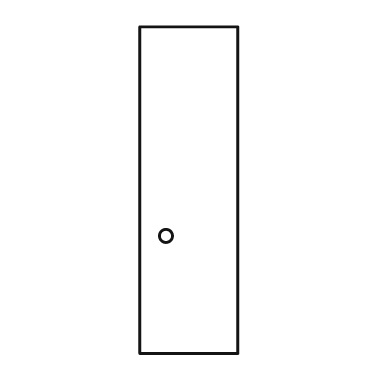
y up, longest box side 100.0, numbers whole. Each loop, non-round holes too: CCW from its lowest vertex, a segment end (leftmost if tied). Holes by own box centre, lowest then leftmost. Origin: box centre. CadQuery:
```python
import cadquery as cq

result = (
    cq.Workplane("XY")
    .moveTo(-15.0, -50.0)
    .lineTo(15.0, -50.0)
    .lineTo(15.0, 50.0)
    .lineTo(-15.0, 50.0)
    .close()
    .moveTo(-7.0, -14.0)
    .circle(2.0)
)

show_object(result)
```